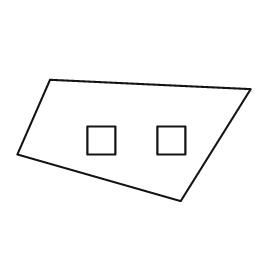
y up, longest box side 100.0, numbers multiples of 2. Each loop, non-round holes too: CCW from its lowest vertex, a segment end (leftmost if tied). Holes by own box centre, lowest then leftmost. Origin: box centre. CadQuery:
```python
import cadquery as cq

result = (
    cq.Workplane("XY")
    .moveTo(20.0, -26.0)
    .lineTo(50.0, 22.0)
    .lineTo(-36.0, 26.0)
    .lineTo(-50.0, -6.0)
    .close()
    .moveTo(-20.0, -6.0)
    .lineTo(-8.0, -6.0)
    .lineTo(-8.0, 6.0)
    .lineTo(-20.0, 6.0)
    .close()
    .moveTo(10.0, -6.0)
    .lineTo(22.0, -6.0)
    .lineTo(22.0, 6.0)
    .lineTo(10.0, 6.0)
    .close()
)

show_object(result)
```